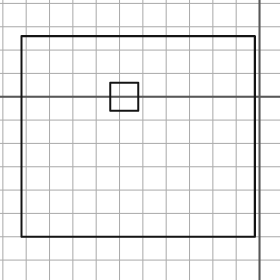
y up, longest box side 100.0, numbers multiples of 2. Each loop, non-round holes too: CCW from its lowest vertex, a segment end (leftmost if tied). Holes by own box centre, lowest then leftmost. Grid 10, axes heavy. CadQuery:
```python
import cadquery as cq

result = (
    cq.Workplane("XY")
    .moveTo(-102.0, -60.0)
    .lineTo(-2.0, -60.0)
    .lineTo(-2.0, 26.0)
    .lineTo(-102.0, 26.0)
    .close()
    .moveTo(-64.0, -6.0)
    .lineTo(-52.0, -6.0)
    .lineTo(-52.0, 6.0)
    .lineTo(-64.0, 6.0)
    .close()
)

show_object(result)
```